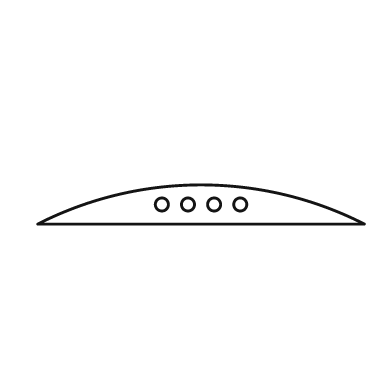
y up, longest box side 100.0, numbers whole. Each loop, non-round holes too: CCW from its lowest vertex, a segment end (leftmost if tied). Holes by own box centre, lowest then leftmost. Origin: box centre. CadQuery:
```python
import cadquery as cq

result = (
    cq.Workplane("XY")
    .moveTo(-50.0, -6.0)
    .lineTo(50.0, -6.0)
    .threePointArc((0.0, 6.0), (-50.0, -6.0))
    .close()
    .moveTo(-12.0, 0.0)
    .circle(2.0)
    .moveTo(-4.0, 0.0)
    .circle(2.0)
    .moveTo(4.0, 0.0)
    .circle(2.0)
    .moveTo(12.0, 0.0)
    .circle(2.0)
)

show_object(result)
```